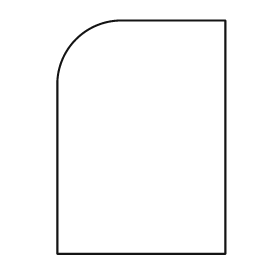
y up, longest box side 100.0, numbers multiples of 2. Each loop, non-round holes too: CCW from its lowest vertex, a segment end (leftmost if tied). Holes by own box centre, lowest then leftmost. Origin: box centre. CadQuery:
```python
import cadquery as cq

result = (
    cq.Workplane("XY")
    .moveTo(-36.0, -50.0)
    .lineTo(36.0, -50.0)
    .lineTo(36.0, 50.0)
    .lineTo(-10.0, 50.0)
    .threePointArc((-28.0, 42.0), (-36.0, 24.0))
    .close()
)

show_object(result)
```